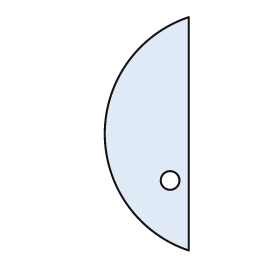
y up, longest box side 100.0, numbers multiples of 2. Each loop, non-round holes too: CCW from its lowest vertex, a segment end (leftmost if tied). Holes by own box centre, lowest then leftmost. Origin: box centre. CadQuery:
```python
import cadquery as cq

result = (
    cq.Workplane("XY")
    .moveTo(18.0, -50.0)
    .lineTo(18.0, 50.0)
    .threePointArc((-18.0, 0.0), (18.0, -50.0))
    .close()
    .moveTo(10.0, -20.0)
    .circle(4.0)
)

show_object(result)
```